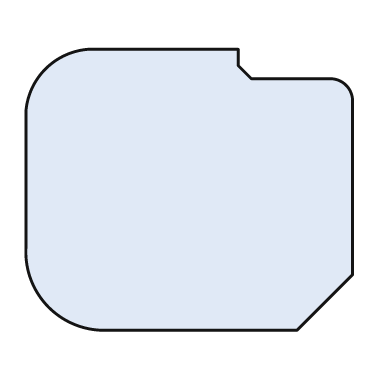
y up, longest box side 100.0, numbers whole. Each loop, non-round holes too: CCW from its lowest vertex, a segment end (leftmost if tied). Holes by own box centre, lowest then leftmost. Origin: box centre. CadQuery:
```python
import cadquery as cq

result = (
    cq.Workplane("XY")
    .moveTo(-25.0, -43.0)
    .lineTo(33.0, -43.0)
    .lineTo(50.0, -26.0)
    .lineTo(50.0, 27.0)
    .threePointArc((48.0, 32.0), (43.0, 34.0))
    .lineTo(19.0, 34.0)
    .lineTo(15.0, 38.0)
    .lineTo(15.0, 43.0)
    .lineTo(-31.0, 43.0)
    .threePointArc((-44.0, 37.0), (-50.0, 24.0))
    .lineTo(-50.0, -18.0)
    .threePointArc((-43.0, -36.0), (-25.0, -43.0))
    .close()
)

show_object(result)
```